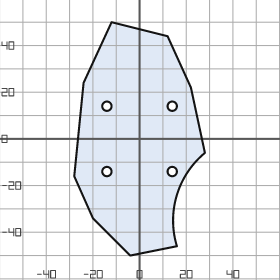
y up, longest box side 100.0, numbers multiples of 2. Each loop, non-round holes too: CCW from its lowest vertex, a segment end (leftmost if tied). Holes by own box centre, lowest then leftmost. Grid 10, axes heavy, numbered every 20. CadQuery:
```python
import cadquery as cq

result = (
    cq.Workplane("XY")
    .moveTo(-4.0, -50.0)
    .lineTo(16.0, -46.0)
    .threePointArc((16.0, -24.0), (28.0, -6.0))
    .lineTo(22.0, 22.0)
    .lineTo(12.0, 44.0)
    .lineTo(-12.0, 50.0)
    .lineTo(-24.0, 24.0)
    .lineTo(-28.0, -16.0)
    .lineTo(-20.0, -34.0)
    .close()
    .moveTo(-14.0, -14.0)
    .circle(2.0)
    .moveTo(14.0, -14.0)
    .circle(2.0)
    .moveTo(-14.0, 14.0)
    .circle(2.0)
    .moveTo(14.0, 14.0)
    .circle(2.0)
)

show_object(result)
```